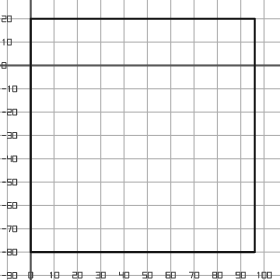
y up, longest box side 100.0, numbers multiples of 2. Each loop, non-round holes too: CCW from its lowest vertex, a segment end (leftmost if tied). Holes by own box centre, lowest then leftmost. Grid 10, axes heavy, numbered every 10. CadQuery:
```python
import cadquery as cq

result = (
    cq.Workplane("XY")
    .moveTo(0.0, -80.0)
    .lineTo(96.0, -80.0)
    .lineTo(96.0, 20.0)
    .lineTo(0.0, 20.0)
    .close()
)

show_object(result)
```